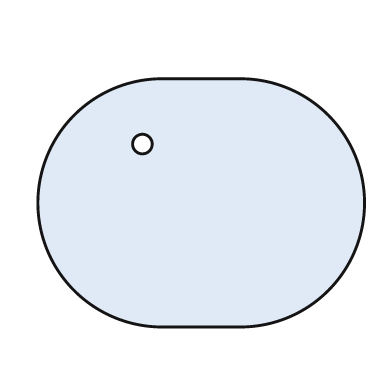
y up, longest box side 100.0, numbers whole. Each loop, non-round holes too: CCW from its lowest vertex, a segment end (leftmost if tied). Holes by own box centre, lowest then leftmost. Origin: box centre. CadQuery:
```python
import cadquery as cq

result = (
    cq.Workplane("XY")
    .moveTo(-12.0, -38.0)
    .lineTo(12.0, -38.0)
    .threePointArc((50.0, 0.0), (12.0, 38.0))
    .lineTo(-12.0, 38.0)
    .threePointArc((-50.0, 0.0), (-12.0, -38.0))
    .close()
    .moveTo(-18.0, 18.0)
    .circle(3.0)
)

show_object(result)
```